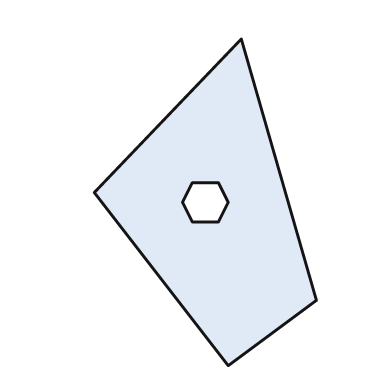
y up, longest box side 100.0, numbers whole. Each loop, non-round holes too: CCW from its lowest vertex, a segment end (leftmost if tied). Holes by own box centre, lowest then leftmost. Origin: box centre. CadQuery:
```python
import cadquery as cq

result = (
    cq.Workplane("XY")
    .moveTo(7.0, -50.0)
    .lineTo(34.0, -30.0)
    .lineTo(11.0, 50.0)
    .lineTo(-34.0, 3.0)
    .close()
    .moveTo(-4.0, -6.0)
    .lineTo(4.0, -6.0)
    .lineTo(7.0, 0.0)
    .lineTo(4.0, 6.0)
    .lineTo(-4.0, 6.0)
    .lineTo(-7.0, 0.0)
    .close()
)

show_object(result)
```